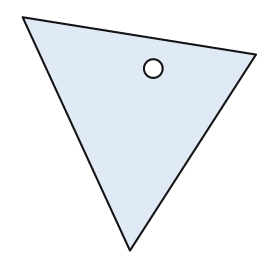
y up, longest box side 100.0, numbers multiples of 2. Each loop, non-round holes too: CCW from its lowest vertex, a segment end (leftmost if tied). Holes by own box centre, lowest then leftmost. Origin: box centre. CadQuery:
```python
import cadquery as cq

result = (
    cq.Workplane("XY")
    .moveTo(-4.0, -50.0)
    .lineTo(50.0, 34.0)
    .lineTo(-50.0, 50.0)
    .close()
    .moveTo(6.0, 28.0)
    .circle(4.0)
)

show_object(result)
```